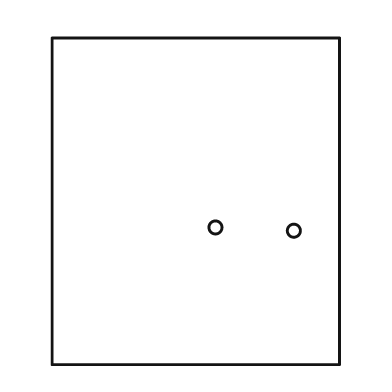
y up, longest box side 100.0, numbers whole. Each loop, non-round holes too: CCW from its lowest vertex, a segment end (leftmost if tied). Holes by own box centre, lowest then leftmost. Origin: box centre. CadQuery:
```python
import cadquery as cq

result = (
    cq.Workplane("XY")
    .moveTo(-44.0, -50.0)
    .lineTo(44.0, -50.0)
    .lineTo(44.0, 50.0)
    .lineTo(-44.0, 50.0)
    .close()
    .moveTo(30.0, -9.0)
    .circle(2.0)
    .moveTo(6.0, -8.0)
    .circle(2.0)
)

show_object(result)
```